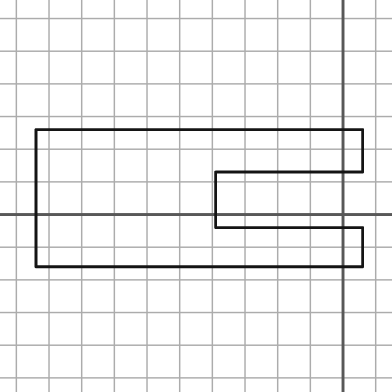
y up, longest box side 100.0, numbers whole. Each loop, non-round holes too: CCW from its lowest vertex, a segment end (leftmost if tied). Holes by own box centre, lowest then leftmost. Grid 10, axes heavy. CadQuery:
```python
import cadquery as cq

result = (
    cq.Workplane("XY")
    .moveTo(-94.0, -16.0)
    .lineTo(6.0, -16.0)
    .lineTo(6.0, -4.0)
    .lineTo(-39.0, -4.0)
    .lineTo(-39.0, 13.0)
    .lineTo(6.0, 13.0)
    .lineTo(6.0, 26.0)
    .lineTo(-94.0, 26.0)
    .close()
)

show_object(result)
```